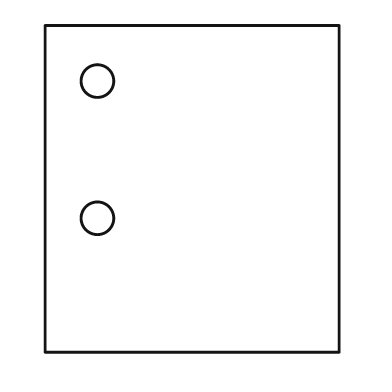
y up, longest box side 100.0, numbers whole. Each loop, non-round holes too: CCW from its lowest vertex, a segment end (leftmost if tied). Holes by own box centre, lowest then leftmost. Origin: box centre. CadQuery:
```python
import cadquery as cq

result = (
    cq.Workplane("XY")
    .moveTo(-45.0, -50.0)
    .lineTo(45.0, -50.0)
    .lineTo(45.0, 50.0)
    .lineTo(-45.0, 50.0)
    .close()
    .moveTo(-29.0, -9.0)
    .circle(5.0)
    .moveTo(-29.0, 33.0)
    .circle(5.0)
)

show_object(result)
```